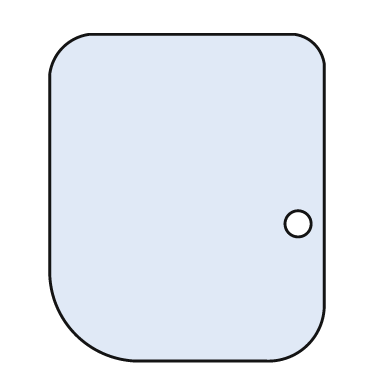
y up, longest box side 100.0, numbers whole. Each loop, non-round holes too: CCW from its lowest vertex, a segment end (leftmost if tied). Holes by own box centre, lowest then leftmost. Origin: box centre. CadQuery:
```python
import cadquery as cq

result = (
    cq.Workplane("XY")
    .moveTo(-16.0, -50.0)
    .lineTo(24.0, -50.0)
    .threePointArc((37.0, -45.0), (42.0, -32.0))
    .lineTo(42.0, 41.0)
    .threePointArc((39.0, 47.0), (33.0, 50.0))
    .lineTo(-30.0, 50.0)
    .threePointArc((-38.0, 46.0), (-42.0, 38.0))
    .lineTo(-42.0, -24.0)
    .threePointArc((-34.0, -42.0), (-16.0, -50.0))
    .close()
    .moveTo(34.0, -8.0)
    .circle(4.0)
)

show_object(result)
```